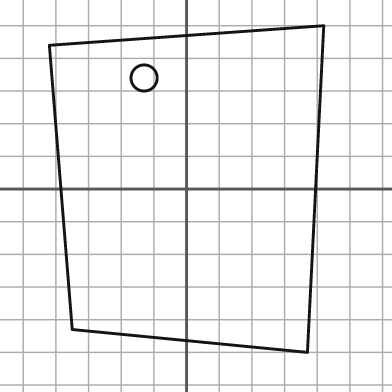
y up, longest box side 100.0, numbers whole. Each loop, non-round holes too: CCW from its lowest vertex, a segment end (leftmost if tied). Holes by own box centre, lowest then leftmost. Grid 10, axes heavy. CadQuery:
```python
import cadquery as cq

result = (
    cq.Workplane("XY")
    .moveTo(37.0, -50.0)
    .lineTo(42.0, 50.0)
    .lineTo(-42.0, 44.0)
    .lineTo(-35.0, -43.0)
    .close()
    .moveTo(-13.0, 34.0)
    .circle(4.0)
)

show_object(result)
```